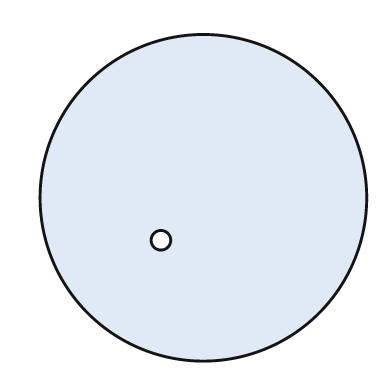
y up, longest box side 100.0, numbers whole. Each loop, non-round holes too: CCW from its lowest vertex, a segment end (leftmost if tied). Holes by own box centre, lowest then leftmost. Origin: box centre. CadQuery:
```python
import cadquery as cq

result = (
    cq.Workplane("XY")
    .moveTo(0.0, 0.0)
    .circle(50.0)
    .moveTo(-13.0, -13.0)
    .circle(3.0)
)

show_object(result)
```